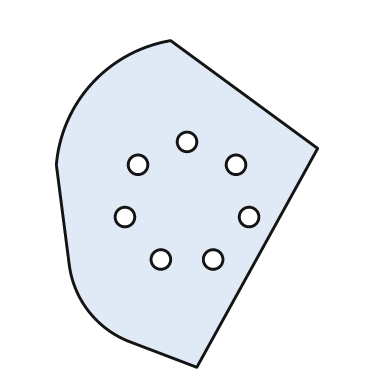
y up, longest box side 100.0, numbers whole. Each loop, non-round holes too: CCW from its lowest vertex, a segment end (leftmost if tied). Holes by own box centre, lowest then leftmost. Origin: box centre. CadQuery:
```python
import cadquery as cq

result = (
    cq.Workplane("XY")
    .moveTo(3.0, -50.0)
    .lineTo(40.0, 17.0)
    .lineTo(-5.0, 50.0)
    .threePointArc((-29.0, 37.0), (-40.0, 12.0))
    .lineTo(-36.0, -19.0)
    .threePointArc((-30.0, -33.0), (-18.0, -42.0))
    .close()
    .moveTo(-8.0, -17.0)
    .circle(3.0)
    .moveTo(8.0, -17.0)
    .circle(3.0)
    .moveTo(-19.0, -4.0)
    .circle(3.0)
    .moveTo(19.0, -4.0)
    .circle(3.0)
    .moveTo(-15.0, 12.0)
    .circle(3.0)
    .moveTo(15.0, 12.0)
    .circle(3.0)
    .moveTo(0.0, 19.0)
    .circle(3.0)
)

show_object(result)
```